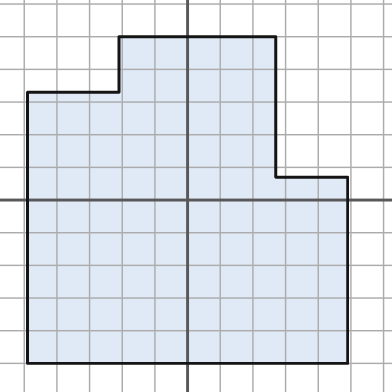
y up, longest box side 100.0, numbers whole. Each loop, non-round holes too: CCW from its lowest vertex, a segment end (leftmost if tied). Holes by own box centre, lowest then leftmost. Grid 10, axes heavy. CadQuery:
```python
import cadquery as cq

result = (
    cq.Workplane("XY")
    .moveTo(-49.0, -50.0)
    .lineTo(49.0, -50.0)
    .lineTo(49.0, 7.0)
    .lineTo(27.0, 7.0)
    .lineTo(27.0, 50.0)
    .lineTo(-21.0, 50.0)
    .lineTo(-21.0, 33.0)
    .lineTo(-49.0, 33.0)
    .close()
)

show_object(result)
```